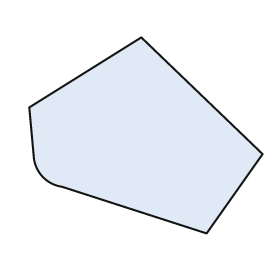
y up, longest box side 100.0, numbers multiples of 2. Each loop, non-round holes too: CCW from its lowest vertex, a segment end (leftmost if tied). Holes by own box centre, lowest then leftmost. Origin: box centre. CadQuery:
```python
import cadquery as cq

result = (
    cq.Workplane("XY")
    .moveTo(26.0, -42.0)
    .lineTo(50.0, -8.0)
    .lineTo(-2.0, 42.0)
    .lineTo(-50.0, 12.0)
    .lineTo(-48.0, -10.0)
    .threePointArc((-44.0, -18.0), (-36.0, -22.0))
    .close()
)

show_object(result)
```